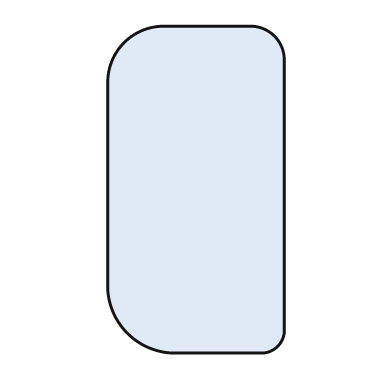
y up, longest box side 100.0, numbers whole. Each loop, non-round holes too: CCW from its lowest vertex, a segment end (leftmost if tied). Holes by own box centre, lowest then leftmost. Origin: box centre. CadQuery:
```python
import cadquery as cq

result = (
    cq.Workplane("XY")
    .moveTo(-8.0, -50.0)
    .lineTo(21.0, -50.0)
    .threePointArc((25.0, -48.0), (27.0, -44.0))
    .lineTo(27.0, 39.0)
    .threePointArc((24.0, 47.0), (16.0, 50.0))
    .lineTo(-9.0, 50.0)
    .threePointArc((-22.0, 45.0), (-27.0, 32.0))
    .lineTo(-27.0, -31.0)
    .threePointArc((-21.0, -44.0), (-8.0, -50.0))
    .close()
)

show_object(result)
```